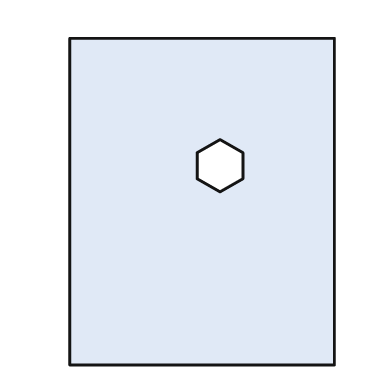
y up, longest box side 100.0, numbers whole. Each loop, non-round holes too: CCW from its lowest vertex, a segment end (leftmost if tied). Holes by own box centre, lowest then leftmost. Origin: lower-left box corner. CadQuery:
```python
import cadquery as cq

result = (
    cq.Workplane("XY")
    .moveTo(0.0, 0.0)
    .lineTo(81.0, 0.0)
    .lineTo(81.0, 100.0)
    .lineTo(0.0, 100.0)
    .close()
    .moveTo(46.0, 53.0)
    .lineTo(53.0, 57.0)
    .lineTo(53.0, 65.0)
    .lineTo(46.0, 69.0)
    .lineTo(39.0, 65.0)
    .lineTo(39.0, 57.0)
    .close()
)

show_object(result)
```